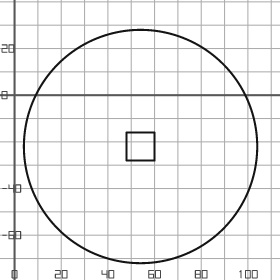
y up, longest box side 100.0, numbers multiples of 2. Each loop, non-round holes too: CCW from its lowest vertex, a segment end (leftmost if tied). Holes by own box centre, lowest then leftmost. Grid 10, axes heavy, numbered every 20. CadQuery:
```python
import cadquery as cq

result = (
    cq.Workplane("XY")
    .moveTo(54.0, -22.0)
    .circle(50.0)
    .moveTo(48.0, -28.0)
    .lineTo(60.0, -28.0)
    .lineTo(60.0, -16.0)
    .lineTo(48.0, -16.0)
    .close()
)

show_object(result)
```